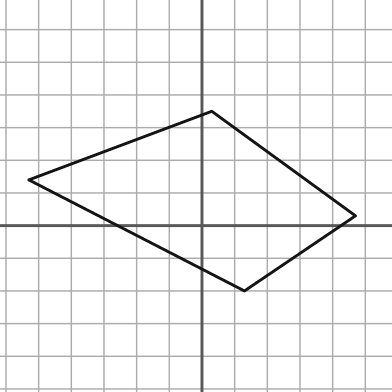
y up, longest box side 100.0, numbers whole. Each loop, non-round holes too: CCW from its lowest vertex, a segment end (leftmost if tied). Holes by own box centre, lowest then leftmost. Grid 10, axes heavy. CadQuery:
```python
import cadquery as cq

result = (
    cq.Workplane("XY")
    .moveTo(13.0, -20.0)
    .lineTo(47.0, 3.0)
    .lineTo(3.0, 35.0)
    .lineTo(-53.0, 14.0)
    .close()
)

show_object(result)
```